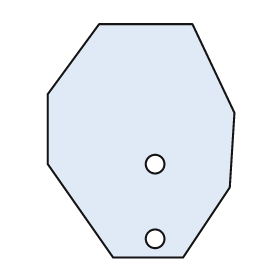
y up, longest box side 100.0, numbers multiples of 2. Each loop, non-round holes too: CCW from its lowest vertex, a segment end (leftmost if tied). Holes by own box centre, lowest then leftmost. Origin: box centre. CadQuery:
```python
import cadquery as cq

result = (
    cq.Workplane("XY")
    .moveTo(-12.0, -50.0)
    .lineTo(18.0, -50.0)
    .lineTo(38.0, -20.0)
    .lineTo(40.0, 12.0)
    .lineTo(22.0, 50.0)
    .lineTo(-18.0, 50.0)
    .lineTo(-40.0, 20.0)
    .lineTo(-40.0, -10.0)
    .close()
    .moveTo(6.0, -42.0)
    .circle(4.0)
    .moveTo(6.0, -10.0)
    .circle(4.0)
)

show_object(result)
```